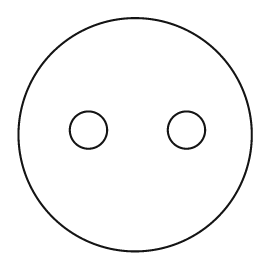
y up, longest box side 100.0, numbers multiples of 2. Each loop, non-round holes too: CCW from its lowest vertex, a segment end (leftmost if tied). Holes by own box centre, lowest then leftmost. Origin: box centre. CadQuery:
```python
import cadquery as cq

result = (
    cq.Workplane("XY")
    .moveTo(0.0, 0.0)
    .circle(50.0)
    .moveTo(-20.0, 2.0)
    .circle(8.0)
    .moveTo(22.0, 2.0)
    .circle(8.0)
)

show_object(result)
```